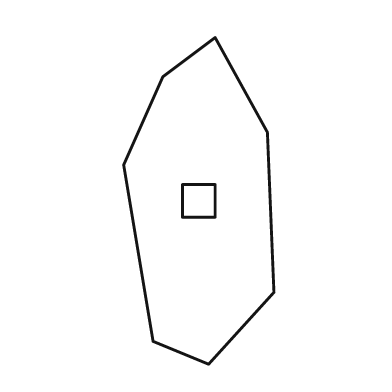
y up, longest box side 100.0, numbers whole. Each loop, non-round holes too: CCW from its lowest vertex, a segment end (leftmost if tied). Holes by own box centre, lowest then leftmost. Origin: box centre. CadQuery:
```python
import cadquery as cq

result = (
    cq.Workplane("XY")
    .moveTo(3.0, -50.0)
    .lineTo(23.0, -28.0)
    .lineTo(21.0, 21.0)
    .lineTo(5.0, 50.0)
    .lineTo(-11.0, 38.0)
    .lineTo(-23.0, 11.0)
    .lineTo(-14.0, -43.0)
    .close()
    .moveTo(-5.0, -5.0)
    .lineTo(5.0, -5.0)
    .lineTo(5.0, 5.0)
    .lineTo(-5.0, 5.0)
    .close()
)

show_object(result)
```